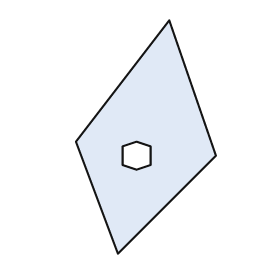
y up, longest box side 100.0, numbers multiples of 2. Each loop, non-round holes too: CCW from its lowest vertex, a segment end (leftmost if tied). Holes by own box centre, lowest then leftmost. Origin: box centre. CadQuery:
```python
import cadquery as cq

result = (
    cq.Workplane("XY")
    .moveTo(-12.0, -50.0)
    .lineTo(30.0, -8.0)
    .lineTo(10.0, 50.0)
    .lineTo(-30.0, -2.0)
    .close()
    .moveTo(-4.0, -14.0)
    .lineTo(2.0, -12.0)
    .lineTo(2.0, -4.0)
    .lineTo(-4.0, -2.0)
    .lineTo(-10.0, -4.0)
    .lineTo(-10.0, -12.0)
    .close()
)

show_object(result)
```